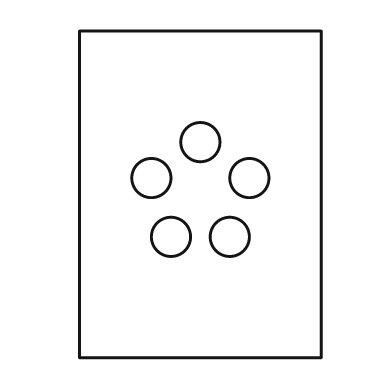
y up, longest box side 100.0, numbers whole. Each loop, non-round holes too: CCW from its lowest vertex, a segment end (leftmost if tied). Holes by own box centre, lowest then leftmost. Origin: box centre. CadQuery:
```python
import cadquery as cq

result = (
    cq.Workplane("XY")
    .moveTo(-37.0, -50.0)
    .lineTo(37.0, -50.0)
    .lineTo(37.0, 50.0)
    .lineTo(-37.0, 50.0)
    .close()
    .moveTo(-9.0, -13.0)
    .circle(6.0)
    .moveTo(9.0, -13.0)
    .circle(6.0)
    .moveTo(-15.0, 5.0)
    .circle(6.0)
    .moveTo(15.0, 5.0)
    .circle(6.0)
    .moveTo(0.0, 16.0)
    .circle(6.0)
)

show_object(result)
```